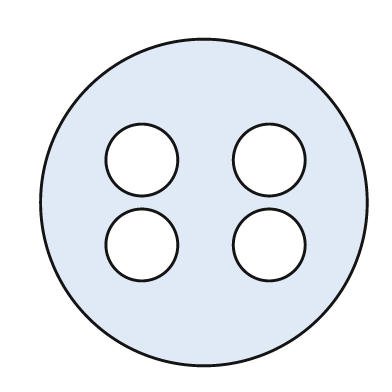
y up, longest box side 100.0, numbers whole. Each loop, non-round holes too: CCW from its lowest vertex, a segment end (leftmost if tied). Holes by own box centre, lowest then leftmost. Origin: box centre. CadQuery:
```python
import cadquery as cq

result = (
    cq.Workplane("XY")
    .moveTo(0.0, 0.0)
    .circle(50.0)
    .moveTo(-19.0, -13.0)
    .circle(11.0)
    .moveTo(20.0, -13.0)
    .circle(11.0)
    .moveTo(-19.0, 13.0)
    .circle(11.0)
    .moveTo(20.0, 13.0)
    .circle(11.0)
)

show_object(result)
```